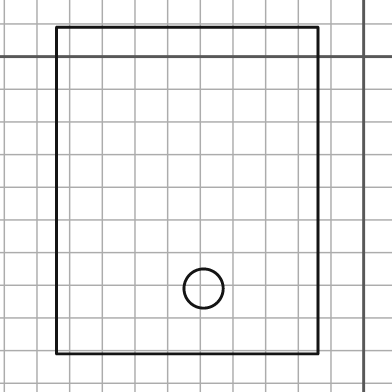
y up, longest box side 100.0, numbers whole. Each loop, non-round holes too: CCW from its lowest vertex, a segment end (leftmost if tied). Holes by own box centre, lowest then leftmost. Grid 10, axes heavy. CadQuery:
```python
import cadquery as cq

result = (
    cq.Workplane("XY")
    .moveTo(-94.0, -91.0)
    .lineTo(-14.0, -91.0)
    .lineTo(-14.0, 9.0)
    .lineTo(-94.0, 9.0)
    .close()
    .moveTo(-49.0, -71.0)
    .circle(6.0)
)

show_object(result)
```